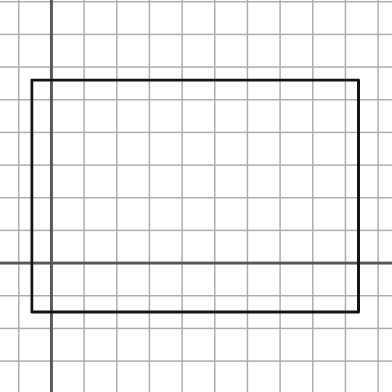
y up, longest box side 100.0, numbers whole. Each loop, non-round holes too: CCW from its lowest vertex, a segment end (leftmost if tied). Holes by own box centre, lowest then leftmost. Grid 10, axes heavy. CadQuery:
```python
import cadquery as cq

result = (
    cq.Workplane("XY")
    .moveTo(-6.0, -15.0)
    .lineTo(94.0, -15.0)
    .lineTo(94.0, 56.0)
    .lineTo(-6.0, 56.0)
    .close()
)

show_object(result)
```